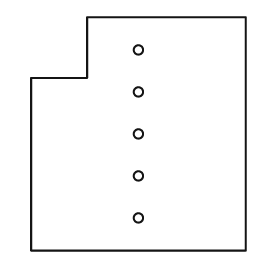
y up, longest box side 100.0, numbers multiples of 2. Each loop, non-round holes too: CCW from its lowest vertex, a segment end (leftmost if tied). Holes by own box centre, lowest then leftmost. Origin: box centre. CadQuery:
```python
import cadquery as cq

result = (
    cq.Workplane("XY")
    .moveTo(-46.0, -50.0)
    .lineTo(46.0, -50.0)
    .lineTo(46.0, 50.0)
    .lineTo(-22.0, 50.0)
    .lineTo(-22.0, 24.0)
    .lineTo(-46.0, 24.0)
    .close()
    .moveTo(0.0, -36.0)
    .circle(2.0)
    .moveTo(0.0, -18.0)
    .circle(2.0)
    .moveTo(0.0, 0.0)
    .circle(2.0)
    .moveTo(0.0, 18.0)
    .circle(2.0)
    .moveTo(0.0, 36.0)
    .circle(2.0)
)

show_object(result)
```